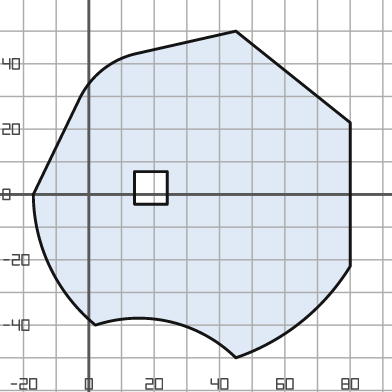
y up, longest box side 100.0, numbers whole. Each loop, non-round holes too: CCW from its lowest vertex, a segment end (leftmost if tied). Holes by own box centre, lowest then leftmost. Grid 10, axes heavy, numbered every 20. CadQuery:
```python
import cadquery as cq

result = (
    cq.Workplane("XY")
    .moveTo(45.0, -50.0)
    .threePointArc((65.0, -39.0), (80.0, -22.0))
    .lineTo(80.0, 22.0)
    .lineTo(45.0, 50.0)
    .lineTo(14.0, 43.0)
    .threePointArc((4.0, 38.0), (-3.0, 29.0))
    .lineTo(-17.0, 0.0)
    .threePointArc((-12.0, -22.0), (2.0, -40.0))
    .threePointArc((25.0, -39.0), (45.0, -50.0))
    .close()
    .moveTo(14.0, -3.0)
    .lineTo(24.0, -3.0)
    .lineTo(24.0, 7.0)
    .lineTo(14.0, 7.0)
    .close()
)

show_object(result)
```